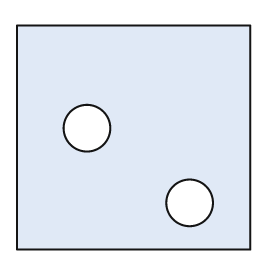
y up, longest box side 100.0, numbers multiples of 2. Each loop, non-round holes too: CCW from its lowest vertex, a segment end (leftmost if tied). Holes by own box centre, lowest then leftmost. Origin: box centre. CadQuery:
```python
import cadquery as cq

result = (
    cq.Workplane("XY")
    .moveTo(-50.0, -48.0)
    .lineTo(50.0, -48.0)
    .lineTo(50.0, 48.0)
    .lineTo(-50.0, 48.0)
    .close()
    .moveTo(24.0, -28.0)
    .circle(10.0)
    .moveTo(-20.0, 4.0)
    .circle(10.0)
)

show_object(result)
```